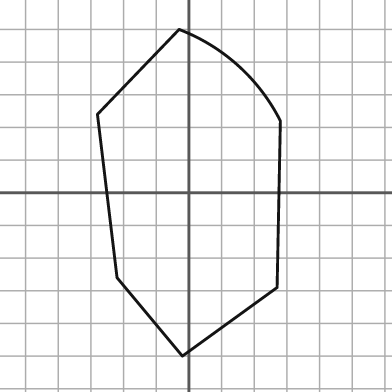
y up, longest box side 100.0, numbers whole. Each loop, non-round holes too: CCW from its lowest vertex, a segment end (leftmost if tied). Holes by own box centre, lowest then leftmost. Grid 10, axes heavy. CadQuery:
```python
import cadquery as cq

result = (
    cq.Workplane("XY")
    .moveTo(-2.0, -50.0)
    .lineTo(27.0, -29.0)
    .lineTo(28.0, 22.0)
    .threePointArc((15.0, 39.0), (-3.0, 50.0))
    .lineTo(-28.0, 24.0)
    .lineTo(-22.0, -26.0)
    .close()
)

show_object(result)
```